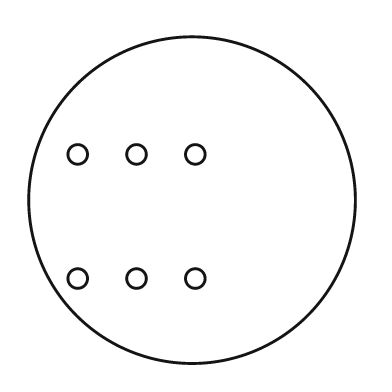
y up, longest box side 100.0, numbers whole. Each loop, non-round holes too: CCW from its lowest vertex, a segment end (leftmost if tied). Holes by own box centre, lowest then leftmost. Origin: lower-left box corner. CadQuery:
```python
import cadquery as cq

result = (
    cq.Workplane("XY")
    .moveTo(50.0, 50.0)
    .circle(50.0)
    .moveTo(15.0, 26.0)
    .circle(3.0)
    .moveTo(33.0, 26.0)
    .circle(3.0)
    .moveTo(51.0, 26.0)
    .circle(3.0)
    .moveTo(15.0, 64.0)
    .circle(3.0)
    .moveTo(33.0, 64.0)
    .circle(3.0)
    .moveTo(51.0, 64.0)
    .circle(3.0)
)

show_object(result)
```